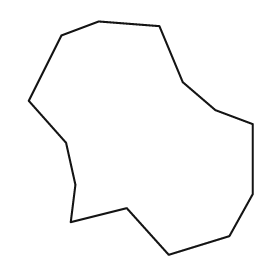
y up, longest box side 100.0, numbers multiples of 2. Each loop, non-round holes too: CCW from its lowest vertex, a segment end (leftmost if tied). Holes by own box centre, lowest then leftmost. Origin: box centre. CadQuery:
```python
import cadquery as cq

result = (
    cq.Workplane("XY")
    .moveTo(12.0, -50.0)
    .lineTo(38.0, -42.0)
    .lineTo(48.0, -24.0)
    .lineTo(48.0, 6.0)
    .lineTo(32.0, 12.0)
    .lineTo(18.0, 24.0)
    .lineTo(8.0, 48.0)
    .lineTo(-18.0, 50.0)
    .lineTo(-34.0, 44.0)
    .lineTo(-48.0, 16.0)
    .lineTo(-32.0, -2.0)
    .lineTo(-28.0, -20.0)
    .lineTo(-30.0, -36.0)
    .lineTo(-6.0, -30.0)
    .close()
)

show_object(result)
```